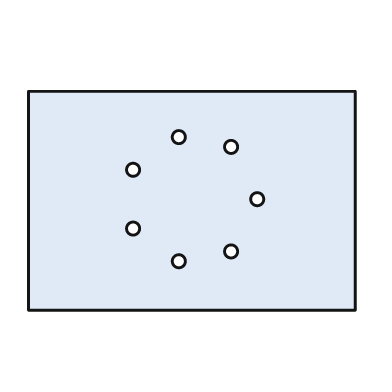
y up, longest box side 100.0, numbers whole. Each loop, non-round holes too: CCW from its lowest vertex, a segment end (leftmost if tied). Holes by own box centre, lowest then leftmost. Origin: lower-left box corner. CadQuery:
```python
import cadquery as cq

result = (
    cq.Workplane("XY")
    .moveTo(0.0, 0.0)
    .lineTo(100.0, 0.0)
    .lineTo(100.0, 67.0)
    .lineTo(0.0, 67.0)
    .close()
    .moveTo(46.0, 15.0)
    .circle(2.0)
    .moveTo(62.0, 18.0)
    .circle(2.0)
    .moveTo(32.0, 25.0)
    .circle(2.0)
    .moveTo(70.0, 34.0)
    .circle(2.0)
    .moveTo(32.0, 43.0)
    .circle(2.0)
    .moveTo(62.0, 50.0)
    .circle(2.0)
    .moveTo(46.0, 53.0)
    .circle(2.0)
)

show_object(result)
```